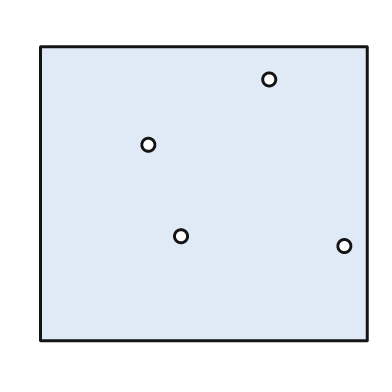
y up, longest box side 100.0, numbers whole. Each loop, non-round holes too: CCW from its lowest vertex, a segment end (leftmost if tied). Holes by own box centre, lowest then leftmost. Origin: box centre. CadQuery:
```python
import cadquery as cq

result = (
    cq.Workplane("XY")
    .moveTo(-50.0, -45.0)
    .lineTo(50.0, -45.0)
    .lineTo(50.0, 45.0)
    .lineTo(-50.0, 45.0)
    .close()
    .moveTo(43.0, -16.0)
    .circle(2.0)
    .moveTo(-7.0, -13.0)
    .circle(2.0)
    .moveTo(-17.0, 15.0)
    .circle(2.0)
    .moveTo(20.0, 35.0)
    .circle(2.0)
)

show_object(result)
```